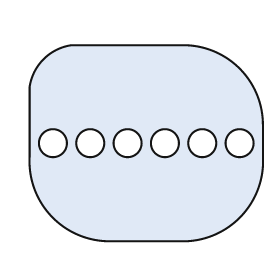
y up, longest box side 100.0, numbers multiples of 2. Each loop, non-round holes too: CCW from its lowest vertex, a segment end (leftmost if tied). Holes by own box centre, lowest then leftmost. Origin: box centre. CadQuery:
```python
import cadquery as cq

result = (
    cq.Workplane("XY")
    .moveTo(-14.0, -42.0)
    .lineTo(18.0, -42.0)
    .threePointArc((40.0, -32.0), (50.0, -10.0))
    .lineTo(50.0, 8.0)
    .threePointArc((40.0, 32.0), (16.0, 42.0))
    .lineTo(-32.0, 42.0)
    .threePointArc((-44.0, 36.0), (-50.0, 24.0))
    .lineTo(-50.0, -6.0)
    .threePointArc((-40.0, -32.0), (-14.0, -42.0))
    .close()
    .moveTo(-40.0, 0.0)
    .circle(6.0)
    .moveTo(-24.0, 0.0)
    .circle(6.0)
    .moveTo(-8.0, 0.0)
    .circle(6.0)
    .moveTo(8.0, 0.0)
    .circle(6.0)
    .moveTo(24.0, 0.0)
    .circle(6.0)
    .moveTo(40.0, 0.0)
    .circle(6.0)
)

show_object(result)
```